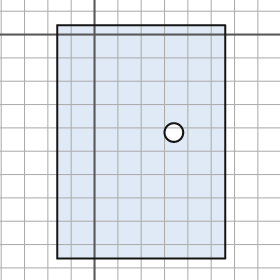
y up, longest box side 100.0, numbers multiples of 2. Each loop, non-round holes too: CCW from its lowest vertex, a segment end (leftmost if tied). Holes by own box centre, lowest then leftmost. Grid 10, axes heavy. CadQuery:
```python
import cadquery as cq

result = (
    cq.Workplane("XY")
    .moveTo(-16.0, -96.0)
    .lineTo(56.0, -96.0)
    .lineTo(56.0, 4.0)
    .lineTo(-16.0, 4.0)
    .close()
    .moveTo(34.0, -42.0)
    .circle(4.0)
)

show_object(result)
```